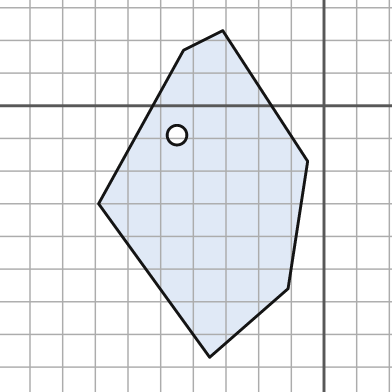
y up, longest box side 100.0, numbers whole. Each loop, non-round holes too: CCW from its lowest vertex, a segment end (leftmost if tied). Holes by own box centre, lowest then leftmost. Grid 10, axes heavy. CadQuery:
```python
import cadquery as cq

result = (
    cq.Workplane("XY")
    .moveTo(-35.0, -77.0)
    .lineTo(-11.0, -56.0)
    .lineTo(-5.0, -17.0)
    .lineTo(-31.0, 23.0)
    .lineTo(-43.0, 17.0)
    .lineTo(-69.0, -30.0)
    .close()
    .moveTo(-45.0, -9.0)
    .circle(3.0)
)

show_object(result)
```